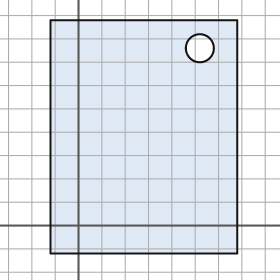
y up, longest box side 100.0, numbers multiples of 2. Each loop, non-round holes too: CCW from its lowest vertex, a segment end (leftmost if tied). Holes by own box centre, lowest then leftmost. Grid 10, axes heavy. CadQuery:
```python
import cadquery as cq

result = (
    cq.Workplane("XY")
    .moveTo(-12.0, -12.0)
    .lineTo(68.0, -12.0)
    .lineTo(68.0, 88.0)
    .lineTo(-12.0, 88.0)
    .close()
    .moveTo(52.0, 76.0)
    .circle(6.0)
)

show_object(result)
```